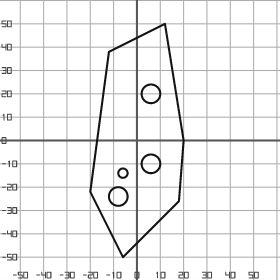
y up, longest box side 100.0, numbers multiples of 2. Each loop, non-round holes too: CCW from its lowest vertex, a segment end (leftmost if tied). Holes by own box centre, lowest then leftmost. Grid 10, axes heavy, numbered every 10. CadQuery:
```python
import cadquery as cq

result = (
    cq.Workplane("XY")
    .moveTo(-6.0, -50.0)
    .lineTo(18.0, -26.0)
    .lineTo(20.0, 0.0)
    .lineTo(12.0, 50.0)
    .lineTo(-12.0, 38.0)
    .lineTo(-20.0, -22.0)
    .close()
    .moveTo(-8.0, -24.0)
    .circle(4.0)
    .moveTo(-6.0, -14.0)
    .circle(2.0)
    .moveTo(6.0, -10.0)
    .circle(4.0)
    .moveTo(6.0, 20.0)
    .circle(4.0)
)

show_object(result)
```